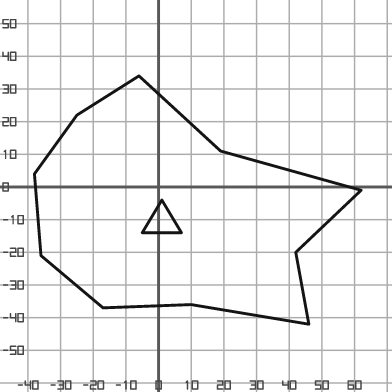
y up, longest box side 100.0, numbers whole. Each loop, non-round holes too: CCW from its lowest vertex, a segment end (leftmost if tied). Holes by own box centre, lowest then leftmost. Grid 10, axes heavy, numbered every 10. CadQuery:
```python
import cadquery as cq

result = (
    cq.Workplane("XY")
    .moveTo(46.0, -42.0)
    .lineTo(42.0, -20.0)
    .lineTo(62.0, -1.0)
    .lineTo(19.0, 11.0)
    .lineTo(-6.0, 34.0)
    .lineTo(-25.0, 22.0)
    .lineTo(-38.0, 4.0)
    .lineTo(-36.0, -21.0)
    .lineTo(-17.0, -37.0)
    .lineTo(10.0, -36.0)
    .close()
    .moveTo(-5.0, -14.0)
    .lineTo(7.0, -14.0)
    .lineTo(1.0, -4.0)
    .close()
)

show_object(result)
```